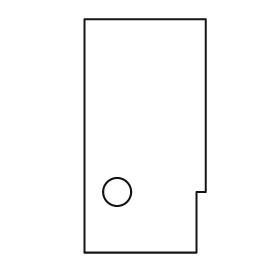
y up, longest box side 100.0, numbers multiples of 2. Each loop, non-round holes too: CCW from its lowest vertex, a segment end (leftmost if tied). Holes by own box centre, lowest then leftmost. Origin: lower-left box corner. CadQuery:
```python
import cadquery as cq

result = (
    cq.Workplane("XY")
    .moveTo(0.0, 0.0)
    .lineTo(48.0, 0.0)
    .lineTo(48.0, 26.0)
    .lineTo(52.0, 26.0)
    .lineTo(52.0, 100.0)
    .lineTo(0.0, 100.0)
    .close()
    .moveTo(14.0, 26.0)
    .circle(6.0)
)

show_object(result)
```